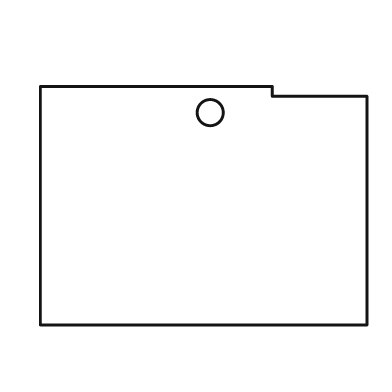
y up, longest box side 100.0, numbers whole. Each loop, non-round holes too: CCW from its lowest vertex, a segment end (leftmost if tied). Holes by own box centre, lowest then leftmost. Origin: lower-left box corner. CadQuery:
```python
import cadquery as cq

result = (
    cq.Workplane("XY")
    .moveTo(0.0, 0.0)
    .lineTo(100.0, 0.0)
    .lineTo(100.0, 70.0)
    .lineTo(71.0, 70.0)
    .lineTo(71.0, 73.0)
    .lineTo(0.0, 73.0)
    .close()
    .moveTo(52.0, 65.0)
    .circle(4.0)
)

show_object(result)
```